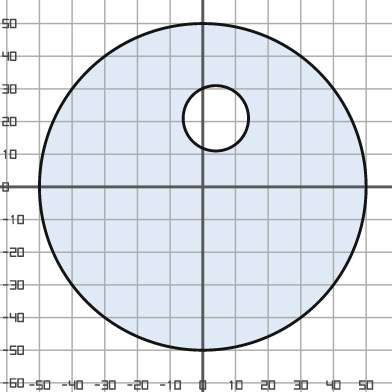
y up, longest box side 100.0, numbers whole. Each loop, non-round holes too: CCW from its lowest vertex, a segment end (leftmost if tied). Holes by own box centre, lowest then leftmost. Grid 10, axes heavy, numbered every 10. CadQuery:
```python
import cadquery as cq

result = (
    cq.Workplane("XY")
    .moveTo(0.0, 0.0)
    .circle(50.0)
    .moveTo(4.0, 21.0)
    .circle(10.0)
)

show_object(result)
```